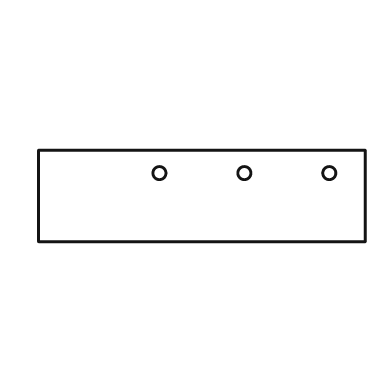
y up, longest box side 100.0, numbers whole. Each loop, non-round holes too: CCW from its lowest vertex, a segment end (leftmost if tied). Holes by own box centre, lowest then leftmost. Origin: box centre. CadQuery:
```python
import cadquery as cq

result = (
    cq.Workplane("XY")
    .moveTo(-50.0, -14.0)
    .lineTo(50.0, -14.0)
    .lineTo(50.0, 14.0)
    .lineTo(-50.0, 14.0)
    .close()
    .moveTo(-13.0, 7.0)
    .circle(2.0)
    .moveTo(13.0, 7.0)
    .circle(2.0)
    .moveTo(39.0, 7.0)
    .circle(2.0)
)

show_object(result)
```